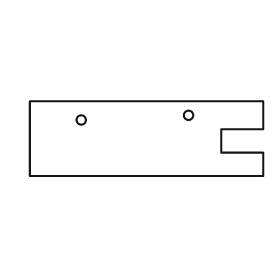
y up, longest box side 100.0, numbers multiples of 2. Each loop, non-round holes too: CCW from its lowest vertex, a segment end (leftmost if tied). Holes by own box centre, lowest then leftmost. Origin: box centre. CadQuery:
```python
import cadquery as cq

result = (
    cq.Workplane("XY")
    .moveTo(-50.0, -16.0)
    .lineTo(50.0, -16.0)
    .lineTo(50.0, -6.0)
    .lineTo(32.0, -6.0)
    .lineTo(32.0, 4.0)
    .lineTo(50.0, 4.0)
    .lineTo(50.0, 16.0)
    .lineTo(-50.0, 16.0)
    .close()
    .moveTo(-28.0, 8.0)
    .circle(2.0)
    .moveTo(18.0, 10.0)
    .circle(2.0)
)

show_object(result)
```